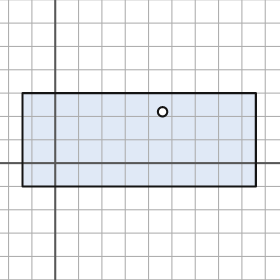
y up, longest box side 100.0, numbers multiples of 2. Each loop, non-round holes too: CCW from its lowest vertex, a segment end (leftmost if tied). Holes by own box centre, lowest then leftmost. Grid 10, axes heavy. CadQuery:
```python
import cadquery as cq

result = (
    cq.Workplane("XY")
    .moveTo(-14.0, -10.0)
    .lineTo(86.0, -10.0)
    .lineTo(86.0, 30.0)
    .lineTo(-14.0, 30.0)
    .close()
    .moveTo(46.0, 22.0)
    .circle(2.0)
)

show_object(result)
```